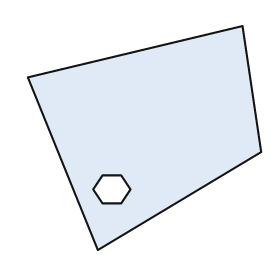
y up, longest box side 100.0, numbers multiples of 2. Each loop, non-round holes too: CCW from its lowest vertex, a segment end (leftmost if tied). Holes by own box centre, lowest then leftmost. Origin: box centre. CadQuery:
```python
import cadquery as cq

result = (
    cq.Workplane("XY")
    .moveTo(-20.0, -48.0)
    .lineTo(50.0, -6.0)
    .lineTo(42.0, 48.0)
    .lineTo(-50.0, 26.0)
    .close()
    .moveTo(-18.0, -28.0)
    .lineTo(-10.0, -28.0)
    .lineTo(-6.0, -22.0)
    .lineTo(-10.0, -16.0)
    .lineTo(-18.0, -16.0)
    .lineTo(-22.0, -22.0)
    .close()
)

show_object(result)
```